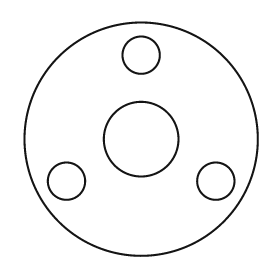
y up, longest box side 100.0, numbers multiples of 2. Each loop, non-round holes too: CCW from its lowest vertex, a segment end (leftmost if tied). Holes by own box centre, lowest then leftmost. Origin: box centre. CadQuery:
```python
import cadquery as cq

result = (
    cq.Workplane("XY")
    .moveTo(0.0, 0.0)
    .circle(50.0)
    .moveTo(-32.0, -18.0)
    .circle(8.0)
    .moveTo(32.0, -18.0)
    .circle(8.0)
    .moveTo(0.0, 0.0)
    .circle(16.0)
    .moveTo(0.0, 36.0)
    .circle(8.0)
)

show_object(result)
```